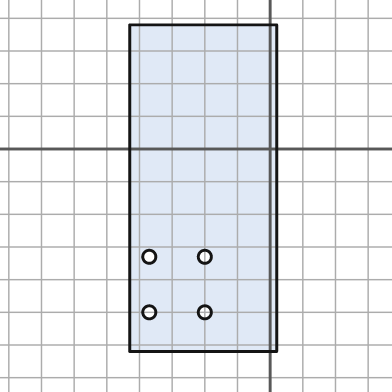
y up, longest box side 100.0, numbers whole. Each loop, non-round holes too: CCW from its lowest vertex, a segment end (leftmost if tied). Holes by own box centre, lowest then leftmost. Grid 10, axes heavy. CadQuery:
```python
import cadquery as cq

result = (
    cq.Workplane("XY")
    .moveTo(-43.0, -62.0)
    .lineTo(2.0, -62.0)
    .lineTo(2.0, 38.0)
    .lineTo(-43.0, 38.0)
    .close()
    .moveTo(-37.0, -50.0)
    .circle(2.0)
    .moveTo(-20.0, -50.0)
    .circle(2.0)
    .moveTo(-37.0, -33.0)
    .circle(2.0)
    .moveTo(-20.0, -33.0)
    .circle(2.0)
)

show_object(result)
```